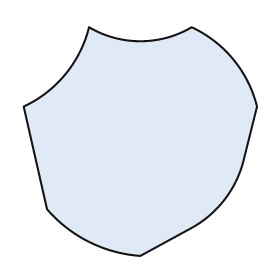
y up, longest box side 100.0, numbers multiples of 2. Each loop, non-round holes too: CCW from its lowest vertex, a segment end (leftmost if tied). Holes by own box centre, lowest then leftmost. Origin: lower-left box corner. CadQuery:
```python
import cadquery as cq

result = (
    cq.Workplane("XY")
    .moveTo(50.0, 0.0)
    .lineTo(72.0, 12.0)
    .threePointArc((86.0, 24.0), (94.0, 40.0))
    .lineTo(100.0, 64.0)
    .threePointArc((90.0, 84.0), (72.0, 98.0))
    .threePointArc((50.0, 92.0), (28.0, 98.0))
    .threePointArc((18.0, 78.0), (0.0, 64.0))
    .lineTo(10.0, 20.0)
    .threePointArc((28.0, 6.0), (50.0, 0.0))
    .close()
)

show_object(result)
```